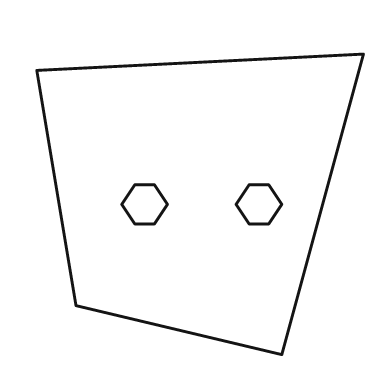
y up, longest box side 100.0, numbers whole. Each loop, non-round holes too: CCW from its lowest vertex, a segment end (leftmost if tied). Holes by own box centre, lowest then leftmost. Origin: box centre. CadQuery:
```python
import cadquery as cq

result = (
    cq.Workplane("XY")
    .moveTo(25.0, -46.0)
    .lineTo(50.0, 46.0)
    .lineTo(-50.0, 41.0)
    .lineTo(-38.0, -31.0)
    .close()
    .moveTo(-20.0, -6.0)
    .lineTo(-14.0, -6.0)
    .lineTo(-10.0, 0.0)
    .lineTo(-14.0, 6.0)
    .lineTo(-20.0, 6.0)
    .lineTo(-24.0, 0.0)
    .close()
    .moveTo(15.0, -6.0)
    .lineTo(21.0, -6.0)
    .lineTo(25.0, 0.0)
    .lineTo(21.0, 6.0)
    .lineTo(15.0, 6.0)
    .lineTo(11.0, 0.0)
    .close()
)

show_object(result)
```